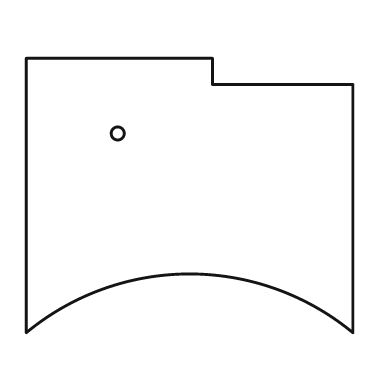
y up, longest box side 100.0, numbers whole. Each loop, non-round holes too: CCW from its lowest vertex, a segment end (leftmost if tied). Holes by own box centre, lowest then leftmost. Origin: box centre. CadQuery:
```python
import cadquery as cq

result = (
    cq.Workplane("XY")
    .moveTo(-50.0, -42.0)
    .threePointArc((0.0, -24.0), (50.0, -42.0))
    .lineTo(50.0, 34.0)
    .lineTo(7.0, 34.0)
    .lineTo(7.0, 42.0)
    .lineTo(-50.0, 42.0)
    .close()
    .moveTo(-22.0, 19.0)
    .circle(2.0)
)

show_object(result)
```